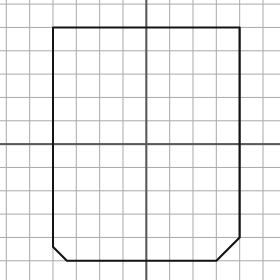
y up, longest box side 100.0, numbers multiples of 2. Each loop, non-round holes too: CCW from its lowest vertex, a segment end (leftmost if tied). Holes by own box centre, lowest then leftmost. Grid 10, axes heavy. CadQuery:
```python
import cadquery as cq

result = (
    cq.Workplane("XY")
    .moveTo(-34.0, -50.0)
    .lineTo(30.0, -50.0)
    .lineTo(40.0, -40.0)
    .lineTo(40.0, 50.0)
    .lineTo(-40.0, 50.0)
    .lineTo(-40.0, -44.0)
    .close()
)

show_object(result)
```